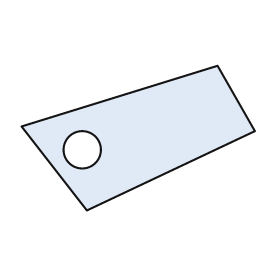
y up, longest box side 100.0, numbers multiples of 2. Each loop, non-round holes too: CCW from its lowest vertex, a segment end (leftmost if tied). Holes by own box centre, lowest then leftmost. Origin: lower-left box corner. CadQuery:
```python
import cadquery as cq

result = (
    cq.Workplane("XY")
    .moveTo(28.0, 0.0)
    .lineTo(100.0, 34.0)
    .lineTo(84.0, 62.0)
    .lineTo(0.0, 36.0)
    .close()
    .moveTo(26.0, 26.0)
    .circle(8.0)
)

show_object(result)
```